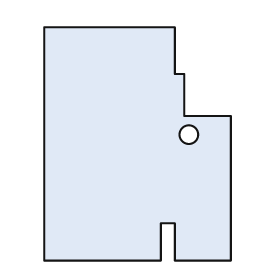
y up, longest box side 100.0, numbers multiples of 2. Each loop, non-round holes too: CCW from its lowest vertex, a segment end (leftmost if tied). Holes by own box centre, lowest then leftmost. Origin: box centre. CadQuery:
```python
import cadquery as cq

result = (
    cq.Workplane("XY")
    .moveTo(-40.0, -50.0)
    .lineTo(10.0, -50.0)
    .lineTo(10.0, -34.0)
    .lineTo(16.0, -34.0)
    .lineTo(16.0, -50.0)
    .lineTo(40.0, -50.0)
    .lineTo(40.0, 12.0)
    .lineTo(20.0, 12.0)
    .lineTo(20.0, 30.0)
    .lineTo(16.0, 30.0)
    .lineTo(16.0, 50.0)
    .lineTo(-40.0, 50.0)
    .close()
    .moveTo(22.0, 4.0)
    .circle(4.0)
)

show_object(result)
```